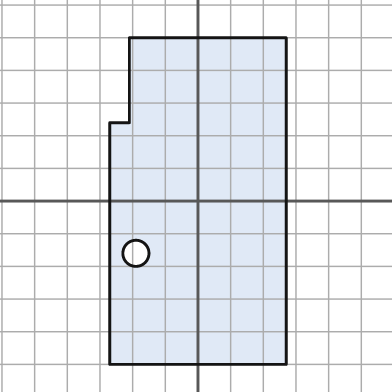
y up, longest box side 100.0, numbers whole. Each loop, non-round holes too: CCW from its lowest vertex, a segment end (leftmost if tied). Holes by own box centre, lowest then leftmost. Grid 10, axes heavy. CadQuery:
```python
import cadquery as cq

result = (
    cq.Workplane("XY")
    .moveTo(-27.0, -50.0)
    .lineTo(27.0, -50.0)
    .lineTo(27.0, 50.0)
    .lineTo(-21.0, 50.0)
    .lineTo(-21.0, 24.0)
    .lineTo(-27.0, 24.0)
    .close()
    .moveTo(-19.0, -16.0)
    .circle(4.0)
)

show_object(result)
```